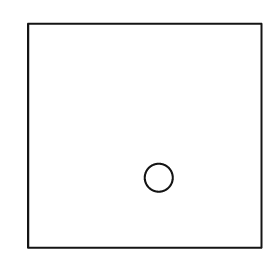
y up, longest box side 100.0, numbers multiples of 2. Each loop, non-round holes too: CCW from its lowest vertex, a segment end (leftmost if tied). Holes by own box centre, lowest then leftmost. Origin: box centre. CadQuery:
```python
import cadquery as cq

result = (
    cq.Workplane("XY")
    .moveTo(-50.0, -48.0)
    .lineTo(50.0, -48.0)
    .lineTo(50.0, 48.0)
    .lineTo(-50.0, 48.0)
    .close()
    .moveTo(6.0, -18.0)
    .circle(6.0)
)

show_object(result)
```